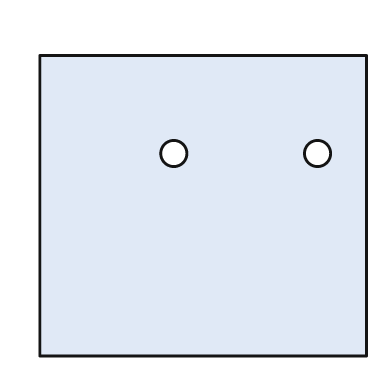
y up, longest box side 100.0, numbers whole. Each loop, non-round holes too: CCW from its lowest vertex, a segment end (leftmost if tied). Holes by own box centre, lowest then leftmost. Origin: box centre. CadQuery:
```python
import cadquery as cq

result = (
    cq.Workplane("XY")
    .moveTo(-50.0, -46.0)
    .lineTo(50.0, -46.0)
    .lineTo(50.0, 46.0)
    .lineTo(-50.0, 46.0)
    .close()
    .moveTo(-9.0, 16.0)
    .circle(4.0)
    .moveTo(35.0, 16.0)
    .circle(4.0)
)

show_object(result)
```